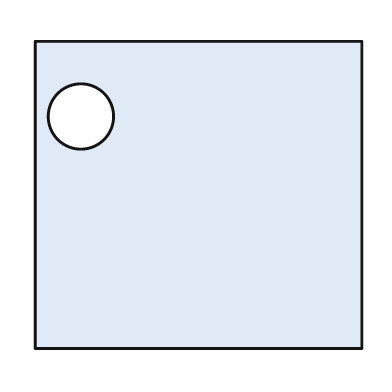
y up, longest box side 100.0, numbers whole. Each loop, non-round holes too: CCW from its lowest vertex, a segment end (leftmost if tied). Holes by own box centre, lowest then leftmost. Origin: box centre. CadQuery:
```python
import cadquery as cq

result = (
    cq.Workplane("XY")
    .moveTo(-50.0, -47.0)
    .lineTo(50.0, -47.0)
    .lineTo(50.0, 47.0)
    .lineTo(-50.0, 47.0)
    .close()
    .moveTo(-36.0, 24.0)
    .circle(10.0)
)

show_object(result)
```